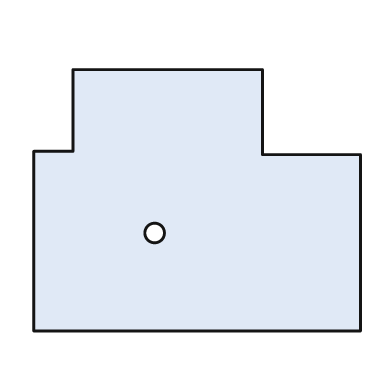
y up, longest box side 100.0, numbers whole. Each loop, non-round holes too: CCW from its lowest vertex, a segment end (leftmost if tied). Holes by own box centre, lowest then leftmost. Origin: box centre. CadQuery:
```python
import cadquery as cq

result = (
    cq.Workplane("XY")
    .moveTo(-50.0, -40.0)
    .lineTo(50.0, -40.0)
    .lineTo(50.0, 14.0)
    .lineTo(20.0, 14.0)
    .lineTo(20.0, 40.0)
    .lineTo(-38.0, 40.0)
    .lineTo(-38.0, 15.0)
    .lineTo(-50.0, 15.0)
    .close()
    .moveTo(-13.0, -10.0)
    .circle(3.0)
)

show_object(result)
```